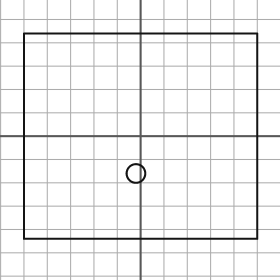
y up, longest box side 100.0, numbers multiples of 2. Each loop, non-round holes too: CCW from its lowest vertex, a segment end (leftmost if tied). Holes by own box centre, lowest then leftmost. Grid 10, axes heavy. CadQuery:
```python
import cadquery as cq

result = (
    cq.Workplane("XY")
    .moveTo(-50.0, -44.0)
    .lineTo(50.0, -44.0)
    .lineTo(50.0, 44.0)
    .lineTo(-50.0, 44.0)
    .close()
    .moveTo(-2.0, -16.0)
    .circle(4.0)
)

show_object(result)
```